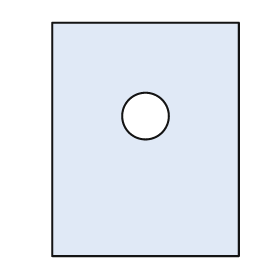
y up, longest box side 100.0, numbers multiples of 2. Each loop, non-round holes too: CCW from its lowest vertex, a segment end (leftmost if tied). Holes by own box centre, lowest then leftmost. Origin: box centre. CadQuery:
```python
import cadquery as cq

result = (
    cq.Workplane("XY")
    .moveTo(-40.0, -50.0)
    .lineTo(40.0, -50.0)
    .lineTo(40.0, 50.0)
    .lineTo(-40.0, 50.0)
    .close()
    .moveTo(0.0, 10.0)
    .circle(10.0)
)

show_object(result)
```